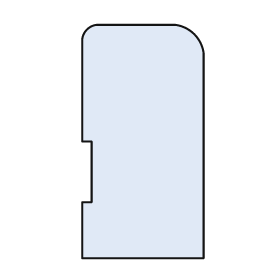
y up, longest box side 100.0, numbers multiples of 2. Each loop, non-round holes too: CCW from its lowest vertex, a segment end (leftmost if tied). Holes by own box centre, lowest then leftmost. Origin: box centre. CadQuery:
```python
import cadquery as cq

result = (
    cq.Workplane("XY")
    .moveTo(-26.0, -50.0)
    .lineTo(26.0, -50.0)
    .lineTo(26.0, 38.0)
    .threePointArc((22.0, 46.0), (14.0, 50.0))
    .lineTo(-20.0, 50.0)
    .threePointArc((-24.0, 48.0), (-26.0, 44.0))
    .lineTo(-26.0, 0.0)
    .lineTo(-22.0, 0.0)
    .lineTo(-22.0, -26.0)
    .lineTo(-26.0, -26.0)
    .close()
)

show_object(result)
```